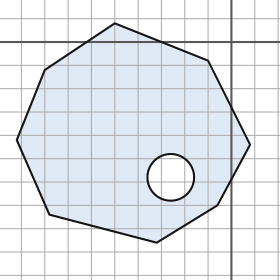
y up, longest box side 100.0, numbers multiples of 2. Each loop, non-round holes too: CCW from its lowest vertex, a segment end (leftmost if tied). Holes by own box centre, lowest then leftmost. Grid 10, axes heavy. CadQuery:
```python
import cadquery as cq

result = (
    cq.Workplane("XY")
    .moveTo(-32.0, -86.0)
    .lineTo(-6.0, -70.0)
    .lineTo(8.0, -44.0)
    .lineTo(-10.0, -8.0)
    .lineTo(-50.0, 8.0)
    .lineTo(-80.0, -12.0)
    .lineTo(-92.0, -42.0)
    .lineTo(-78.0, -74.0)
    .close()
    .moveTo(-26.0, -58.0)
    .circle(10.0)
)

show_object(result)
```